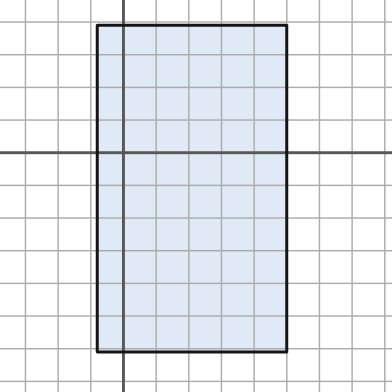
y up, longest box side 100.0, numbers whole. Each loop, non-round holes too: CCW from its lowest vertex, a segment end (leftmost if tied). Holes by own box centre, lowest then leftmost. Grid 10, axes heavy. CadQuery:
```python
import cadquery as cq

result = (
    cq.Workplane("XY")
    .moveTo(-8.0, -61.0)
    .lineTo(50.0, -61.0)
    .lineTo(50.0, 39.0)
    .lineTo(-8.0, 39.0)
    .close()
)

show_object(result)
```